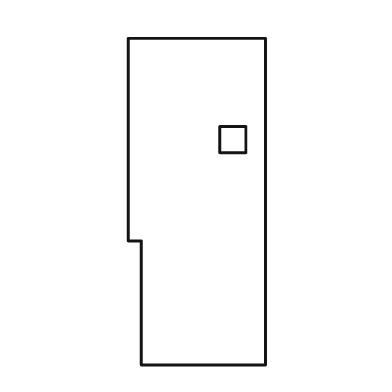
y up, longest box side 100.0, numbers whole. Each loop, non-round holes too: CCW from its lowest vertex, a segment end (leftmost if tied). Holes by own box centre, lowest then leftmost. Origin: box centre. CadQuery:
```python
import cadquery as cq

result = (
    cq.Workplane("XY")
    .moveTo(-17.0, -50.0)
    .lineTo(21.0, -50.0)
    .lineTo(21.0, 50.0)
    .lineTo(-21.0, 50.0)
    .lineTo(-21.0, -12.0)
    .lineTo(-17.0, -12.0)
    .close()
    .moveTo(7.0, 15.0)
    .lineTo(15.0, 15.0)
    .lineTo(15.0, 23.0)
    .lineTo(7.0, 23.0)
    .close()
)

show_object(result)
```